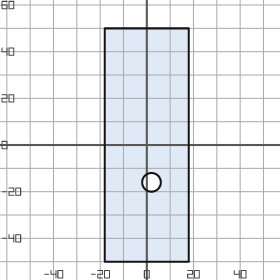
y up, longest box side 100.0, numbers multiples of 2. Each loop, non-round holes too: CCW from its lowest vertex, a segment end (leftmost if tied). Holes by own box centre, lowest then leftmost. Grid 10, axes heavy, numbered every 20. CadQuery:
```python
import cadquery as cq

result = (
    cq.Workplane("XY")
    .moveTo(-18.0, -50.0)
    .lineTo(18.0, -50.0)
    .lineTo(18.0, 50.0)
    .lineTo(-18.0, 50.0)
    .close()
    .moveTo(2.0, -16.0)
    .circle(4.0)
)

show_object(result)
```